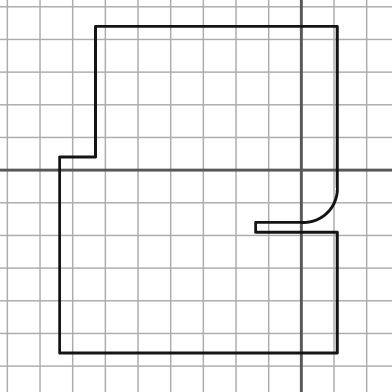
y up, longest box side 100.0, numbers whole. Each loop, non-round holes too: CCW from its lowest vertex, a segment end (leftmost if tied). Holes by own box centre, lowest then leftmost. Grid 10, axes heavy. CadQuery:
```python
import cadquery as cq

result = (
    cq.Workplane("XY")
    .moveTo(-74.0, -56.0)
    .lineTo(11.0, -56.0)
    .lineTo(11.0, -19.0)
    .lineTo(-14.0, -19.0)
    .lineTo(-14.0, -16.0)
    .lineTo(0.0, -16.0)
    .threePointArc((8.0, -13.0), (11.0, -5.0))
    .lineTo(11.0, 44.0)
    .lineTo(-63.0, 44.0)
    .lineTo(-63.0, 4.0)
    .lineTo(-74.0, 4.0)
    .close()
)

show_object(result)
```